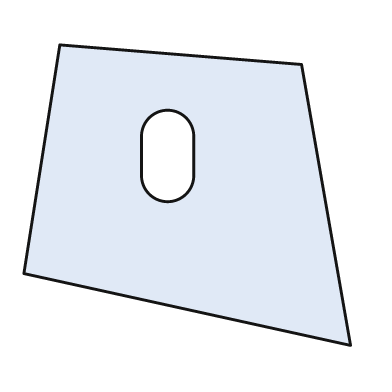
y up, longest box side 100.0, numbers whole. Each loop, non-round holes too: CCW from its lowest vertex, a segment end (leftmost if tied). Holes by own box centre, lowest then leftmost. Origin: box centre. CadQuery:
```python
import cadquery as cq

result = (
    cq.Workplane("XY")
    .moveTo(50.0, -46.0)
    .lineTo(35.0, 40.0)
    .lineTo(-39.0, 46.0)
    .lineTo(-50.0, -24.0)
    .close()
    .moveTo(-14.0, 6.0)
    .threePointArc((-6.0, -2.0), (2.0, 6.0))
    .lineTo(2.0, 18.0)
    .threePointArc((-6.0, 26.0), (-14.0, 18.0))
    .close()
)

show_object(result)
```